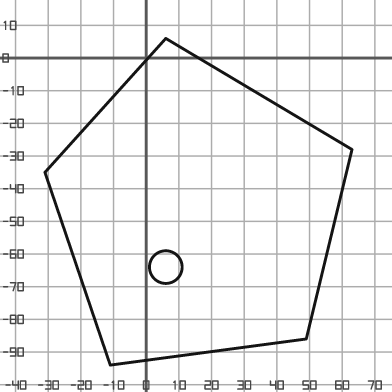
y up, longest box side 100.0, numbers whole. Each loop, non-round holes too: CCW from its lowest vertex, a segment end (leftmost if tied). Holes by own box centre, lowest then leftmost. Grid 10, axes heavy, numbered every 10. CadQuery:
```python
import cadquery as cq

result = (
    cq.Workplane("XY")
    .moveTo(-11.0, -94.0)
    .lineTo(49.0, -86.0)
    .lineTo(63.0, -28.0)
    .lineTo(6.0, 6.0)
    .lineTo(-31.0, -35.0)
    .close()
    .moveTo(6.0, -64.0)
    .circle(5.0)
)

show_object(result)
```